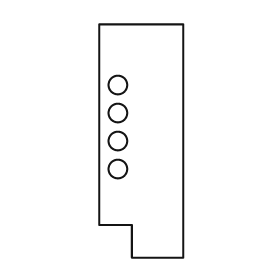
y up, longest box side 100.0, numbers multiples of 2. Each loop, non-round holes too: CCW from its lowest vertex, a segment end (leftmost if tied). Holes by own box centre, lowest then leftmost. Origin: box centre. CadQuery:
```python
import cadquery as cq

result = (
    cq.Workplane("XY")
    .moveTo(-4.0, -50.0)
    .lineTo(18.0, -50.0)
    .lineTo(18.0, 50.0)
    .lineTo(-18.0, 50.0)
    .lineTo(-18.0, -36.0)
    .lineTo(-4.0, -36.0)
    .close()
    .moveTo(-10.0, -12.0)
    .circle(4.0)
    .moveTo(-10.0, 0.0)
    .circle(4.0)
    .moveTo(-10.0, 12.0)
    .circle(4.0)
    .moveTo(-10.0, 24.0)
    .circle(4.0)
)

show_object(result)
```